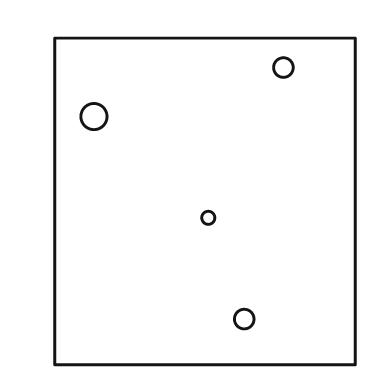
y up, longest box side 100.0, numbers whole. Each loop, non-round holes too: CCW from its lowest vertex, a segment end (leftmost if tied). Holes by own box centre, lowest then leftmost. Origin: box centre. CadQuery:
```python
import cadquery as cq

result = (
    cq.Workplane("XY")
    .moveTo(-46.0, -50.0)
    .lineTo(46.0, -50.0)
    .lineTo(46.0, 50.0)
    .lineTo(-46.0, 50.0)
    .close()
    .moveTo(12.0, -36.0)
    .circle(3.0)
    .moveTo(1.0, -5.0)
    .circle(2.0)
    .moveTo(-34.0, 26.0)
    .circle(4.0)
    .moveTo(24.0, 41.0)
    .circle(3.0)
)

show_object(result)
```